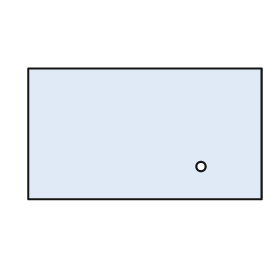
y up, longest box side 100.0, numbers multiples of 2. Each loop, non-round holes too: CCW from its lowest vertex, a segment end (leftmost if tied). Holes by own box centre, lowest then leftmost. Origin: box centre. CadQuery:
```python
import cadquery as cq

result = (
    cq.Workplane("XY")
    .moveTo(-50.0, -28.0)
    .lineTo(50.0, -28.0)
    .lineTo(50.0, 28.0)
    .lineTo(-50.0, 28.0)
    .close()
    .moveTo(24.0, -14.0)
    .circle(2.0)
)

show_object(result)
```